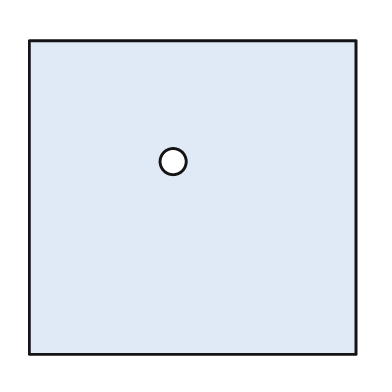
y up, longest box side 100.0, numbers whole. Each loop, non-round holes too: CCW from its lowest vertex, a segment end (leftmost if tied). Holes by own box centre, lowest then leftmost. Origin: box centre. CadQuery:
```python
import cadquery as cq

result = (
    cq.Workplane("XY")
    .moveTo(-50.0, -48.0)
    .lineTo(50.0, -48.0)
    .lineTo(50.0, 48.0)
    .lineTo(-50.0, 48.0)
    .close()
    .moveTo(-6.0, 11.0)
    .circle(4.0)
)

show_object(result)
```